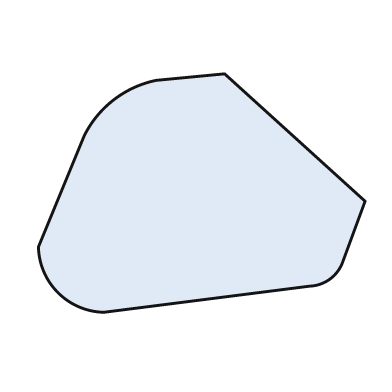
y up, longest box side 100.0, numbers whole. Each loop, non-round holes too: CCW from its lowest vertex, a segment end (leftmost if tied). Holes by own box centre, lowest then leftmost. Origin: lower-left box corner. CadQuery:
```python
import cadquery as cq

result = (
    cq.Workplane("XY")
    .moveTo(20.0, 0.0)
    .lineTo(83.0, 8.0)
    .threePointArc((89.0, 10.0), (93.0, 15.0))
    .lineTo(100.0, 34.0)
    .lineTo(57.0, 73.0)
    .lineTo(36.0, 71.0)
    .threePointArc((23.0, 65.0), (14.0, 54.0))
    .lineTo(0.0, 20.0)
    .threePointArc((6.0, 6.0), (20.0, 0.0))
    .close()
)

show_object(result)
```